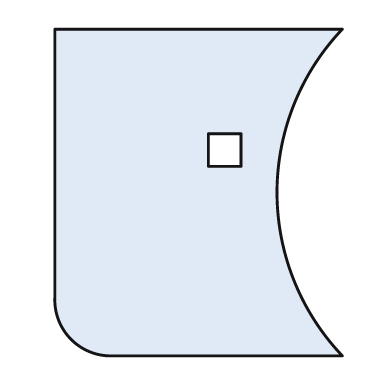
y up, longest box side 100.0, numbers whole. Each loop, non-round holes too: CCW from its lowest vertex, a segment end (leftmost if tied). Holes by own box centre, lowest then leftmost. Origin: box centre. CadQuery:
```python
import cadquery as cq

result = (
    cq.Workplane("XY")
    .moveTo(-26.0, -50.0)
    .lineTo(44.0, -50.0)
    .threePointArc((24.0, 0.0), (44.0, 50.0))
    .lineTo(-44.0, 50.0)
    .lineTo(-44.0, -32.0)
    .threePointArc((-39.0, -45.0), (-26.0, -50.0))
    .close()
    .moveTo(3.0, 8.0)
    .lineTo(13.0, 8.0)
    .lineTo(13.0, 18.0)
    .lineTo(3.0, 18.0)
    .close()
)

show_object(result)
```